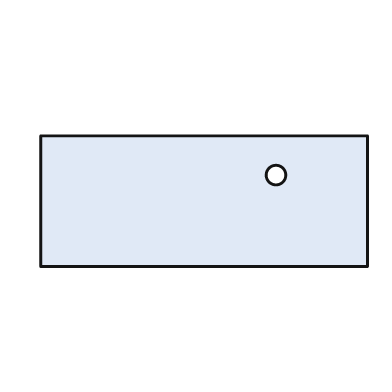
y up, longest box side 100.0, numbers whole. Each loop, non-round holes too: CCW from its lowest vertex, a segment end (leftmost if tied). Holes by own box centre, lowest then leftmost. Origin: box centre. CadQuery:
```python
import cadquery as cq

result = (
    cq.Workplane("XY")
    .moveTo(-50.0, -20.0)
    .lineTo(50.0, -20.0)
    .lineTo(50.0, 20.0)
    .lineTo(-50.0, 20.0)
    .close()
    .moveTo(22.0, 8.0)
    .circle(3.0)
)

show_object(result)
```